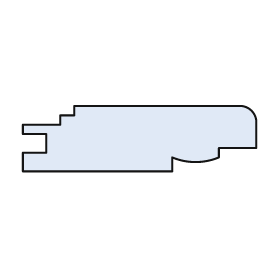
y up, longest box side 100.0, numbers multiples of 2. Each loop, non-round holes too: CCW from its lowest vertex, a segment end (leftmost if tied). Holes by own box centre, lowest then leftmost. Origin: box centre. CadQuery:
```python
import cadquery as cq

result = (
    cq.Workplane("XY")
    .moveTo(-50.0, -14.0)
    .lineTo(14.0, -14.0)
    .lineTo(14.0, -8.0)
    .threePointArc((24.0, -10.0), (34.0, -8.0))
    .lineTo(34.0, -4.0)
    .lineTo(50.0, -4.0)
    .lineTo(50.0, 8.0)
    .threePointArc((48.0, 12.0), (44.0, 14.0))
    .lineTo(-28.0, 14.0)
    .lineTo(-28.0, 10.0)
    .lineTo(-34.0, 10.0)
    .lineTo(-34.0, 6.0)
    .lineTo(-50.0, 6.0)
    .lineTo(-50.0, 2.0)
    .lineTo(-40.0, 2.0)
    .lineTo(-40.0, -6.0)
    .lineTo(-50.0, -6.0)
    .close()
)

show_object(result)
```